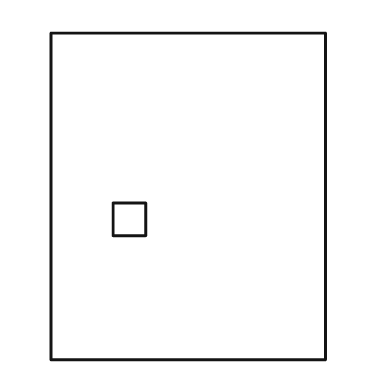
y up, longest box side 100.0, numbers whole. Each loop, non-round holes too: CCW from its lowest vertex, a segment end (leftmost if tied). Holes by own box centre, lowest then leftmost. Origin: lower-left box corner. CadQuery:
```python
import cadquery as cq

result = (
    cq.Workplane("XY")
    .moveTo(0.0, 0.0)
    .lineTo(84.0, 0.0)
    .lineTo(84.0, 100.0)
    .lineTo(0.0, 100.0)
    .close()
    .moveTo(19.0, 38.0)
    .lineTo(29.0, 38.0)
    .lineTo(29.0, 48.0)
    .lineTo(19.0, 48.0)
    .close()
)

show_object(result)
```